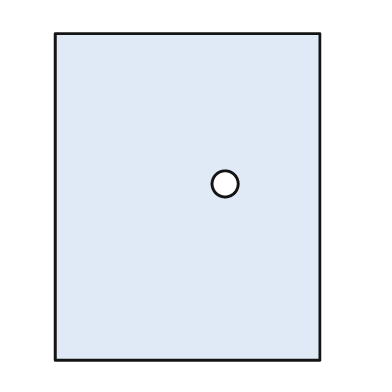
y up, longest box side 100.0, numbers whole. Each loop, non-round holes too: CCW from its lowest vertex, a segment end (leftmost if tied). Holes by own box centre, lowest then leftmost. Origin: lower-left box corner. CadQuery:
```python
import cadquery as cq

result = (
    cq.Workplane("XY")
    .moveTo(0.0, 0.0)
    .lineTo(81.0, 0.0)
    .lineTo(81.0, 100.0)
    .lineTo(0.0, 100.0)
    .close()
    .moveTo(52.0, 54.0)
    .circle(4.0)
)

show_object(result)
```